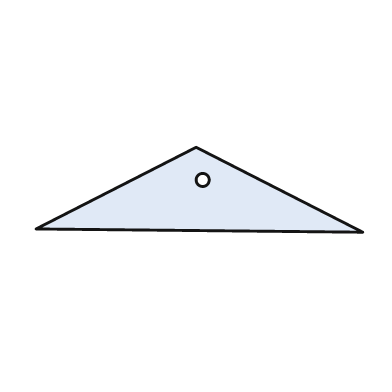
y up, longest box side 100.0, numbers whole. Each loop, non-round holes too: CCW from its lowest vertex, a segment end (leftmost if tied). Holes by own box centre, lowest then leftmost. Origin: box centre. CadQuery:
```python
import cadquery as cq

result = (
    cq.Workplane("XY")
    .moveTo(50.0, -13.0)
    .lineTo(-1.0, 13.0)
    .lineTo(-50.0, -12.0)
    .close()
    .moveTo(1.0, 3.0)
    .circle(2.0)
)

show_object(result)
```